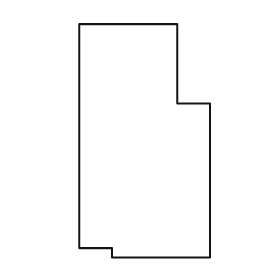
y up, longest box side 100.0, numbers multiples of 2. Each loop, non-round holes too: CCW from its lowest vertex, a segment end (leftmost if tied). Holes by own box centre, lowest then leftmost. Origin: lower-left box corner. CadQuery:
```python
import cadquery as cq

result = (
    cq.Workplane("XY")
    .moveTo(14.0, 0.0)
    .lineTo(56.0, 0.0)
    .lineTo(56.0, 66.0)
    .lineTo(42.0, 66.0)
    .lineTo(42.0, 100.0)
    .lineTo(0.0, 100.0)
    .lineTo(0.0, 4.0)
    .lineTo(14.0, 4.0)
    .close()
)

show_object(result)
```